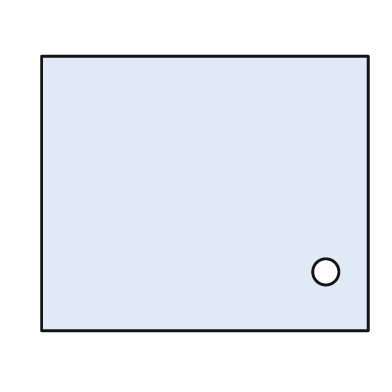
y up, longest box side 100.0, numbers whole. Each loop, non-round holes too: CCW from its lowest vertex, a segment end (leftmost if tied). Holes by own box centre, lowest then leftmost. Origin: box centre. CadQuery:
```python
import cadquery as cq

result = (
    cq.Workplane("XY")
    .moveTo(-50.0, -42.0)
    .lineTo(50.0, -42.0)
    .lineTo(50.0, 42.0)
    .lineTo(-50.0, 42.0)
    .close()
    .moveTo(37.0, -24.0)
    .circle(4.0)
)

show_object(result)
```